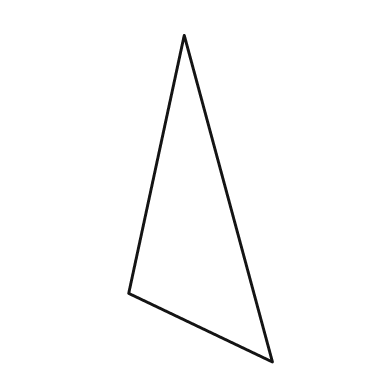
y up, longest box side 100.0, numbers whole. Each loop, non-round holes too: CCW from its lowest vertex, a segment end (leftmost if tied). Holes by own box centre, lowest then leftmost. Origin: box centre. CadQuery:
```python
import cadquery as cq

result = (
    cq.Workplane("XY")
    .moveTo(22.0, -50.0)
    .lineTo(-5.0, 50.0)
    .lineTo(-22.0, -29.0)
    .close()
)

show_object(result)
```